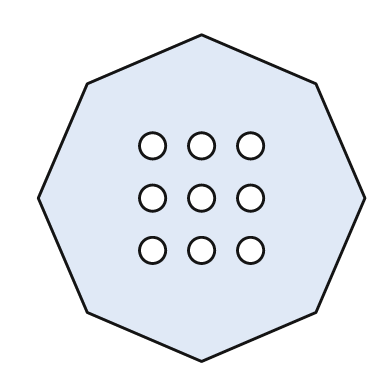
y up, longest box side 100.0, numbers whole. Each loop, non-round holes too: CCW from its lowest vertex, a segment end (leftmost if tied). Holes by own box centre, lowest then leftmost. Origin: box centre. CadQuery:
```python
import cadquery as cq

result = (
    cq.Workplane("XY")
    .moveTo(0.0, -50.0)
    .lineTo(35.0, -35.0)
    .lineTo(50.0, 0.0)
    .lineTo(35.0, 35.0)
    .lineTo(0.0, 50.0)
    .lineTo(-35.0, 35.0)
    .lineTo(-50.0, 0.0)
    .lineTo(-35.0, -35.0)
    .close()
    .moveTo(-15.0, -16.0)
    .circle(4.0)
    .moveTo(0.0, -16.0)
    .circle(4.0)
    .moveTo(15.0, -16.0)
    .circle(4.0)
    .moveTo(-15.0, 0.0)
    .circle(4.0)
    .moveTo(0.0, 0.0)
    .circle(4.0)
    .moveTo(15.0, 0.0)
    .circle(4.0)
    .moveTo(-15.0, 16.0)
    .circle(4.0)
    .moveTo(0.0, 16.0)
    .circle(4.0)
    .moveTo(15.0, 16.0)
    .circle(4.0)
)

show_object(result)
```